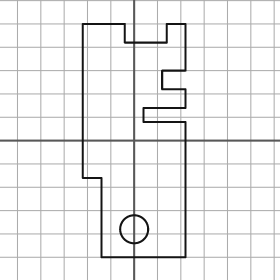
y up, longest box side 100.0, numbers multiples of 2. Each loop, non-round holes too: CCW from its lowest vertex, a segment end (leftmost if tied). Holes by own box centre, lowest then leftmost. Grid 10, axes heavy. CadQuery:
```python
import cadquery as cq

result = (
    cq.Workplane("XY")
    .moveTo(-14.0, -50.0)
    .lineTo(22.0, -50.0)
    .lineTo(22.0, 8.0)
    .lineTo(4.0, 8.0)
    .lineTo(4.0, 14.0)
    .lineTo(22.0, 14.0)
    .lineTo(22.0, 22.0)
    .lineTo(12.0, 22.0)
    .lineTo(12.0, 30.0)
    .lineTo(22.0, 30.0)
    .lineTo(22.0, 50.0)
    .lineTo(14.0, 50.0)
    .lineTo(14.0, 42.0)
    .lineTo(-4.0, 42.0)
    .lineTo(-4.0, 50.0)
    .lineTo(-22.0, 50.0)
    .lineTo(-22.0, -16.0)
    .lineTo(-14.0, -16.0)
    .close()
    .moveTo(0.0, -38.0)
    .circle(6.0)
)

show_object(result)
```